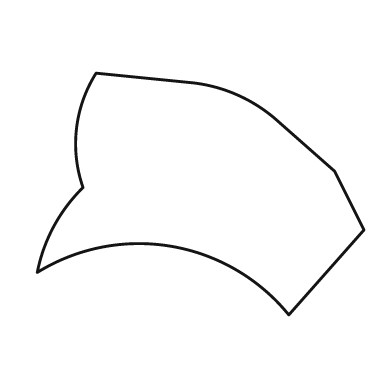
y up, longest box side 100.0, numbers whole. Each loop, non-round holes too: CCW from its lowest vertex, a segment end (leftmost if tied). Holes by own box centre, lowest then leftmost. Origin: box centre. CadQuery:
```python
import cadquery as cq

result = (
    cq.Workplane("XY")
    .moveTo(27.0, -37.0)
    .lineTo(50.0, -11.0)
    .lineTo(41.0, 7.0)
    .lineTo(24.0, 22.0)
    .threePointArc((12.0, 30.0), (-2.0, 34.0))
    .lineTo(-32.0, 37.0)
    .threePointArc((-38.0, 20.0), (-36.0, 2.0))
    .threePointArc((-45.0, -10.0), (-50.0, -24.0))
    .threePointArc((-9.0, -16.0), (27.0, -37.0))
    .close()
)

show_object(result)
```